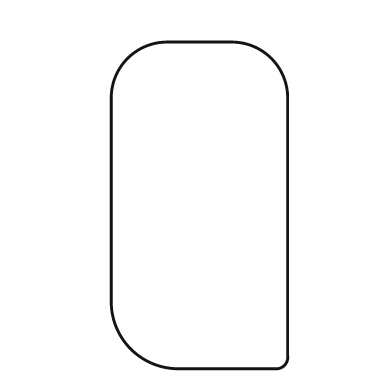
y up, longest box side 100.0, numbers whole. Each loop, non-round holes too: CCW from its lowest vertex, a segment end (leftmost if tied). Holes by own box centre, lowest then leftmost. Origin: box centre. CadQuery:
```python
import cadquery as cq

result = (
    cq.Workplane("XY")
    .moveTo(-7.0, -50.0)
    .lineTo(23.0, -50.0)
    .threePointArc((26.0, -49.0), (27.0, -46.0))
    .lineTo(27.0, 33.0)
    .threePointArc((22.0, 45.0), (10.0, 50.0))
    .lineTo(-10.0, 50.0)
    .threePointArc((-22.0, 45.0), (-27.0, 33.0))
    .lineTo(-27.0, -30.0)
    .threePointArc((-21.0, -44.0), (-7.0, -50.0))
    .close()
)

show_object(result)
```